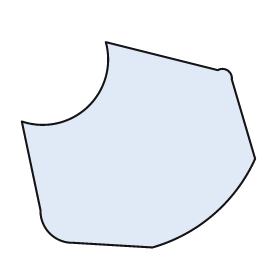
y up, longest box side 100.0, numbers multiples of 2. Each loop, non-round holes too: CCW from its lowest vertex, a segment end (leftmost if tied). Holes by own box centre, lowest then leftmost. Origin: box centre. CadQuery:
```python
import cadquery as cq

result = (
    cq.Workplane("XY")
    .moveTo(6.0, -44.0)
    .threePointArc((32.0, -30.0), (50.0, -6.0))
    .lineTo(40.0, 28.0)
    .threePointArc((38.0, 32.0), (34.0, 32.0))
    .lineTo(-14.0, 44.0)
    .threePointArc((-22.0, 16.0), (-50.0, 10.0))
    .lineTo(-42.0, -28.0)
    .threePointArc((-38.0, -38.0), (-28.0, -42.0))
    .close()
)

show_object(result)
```